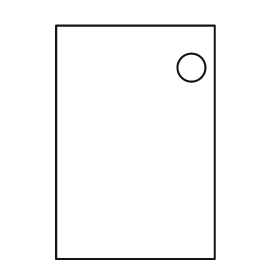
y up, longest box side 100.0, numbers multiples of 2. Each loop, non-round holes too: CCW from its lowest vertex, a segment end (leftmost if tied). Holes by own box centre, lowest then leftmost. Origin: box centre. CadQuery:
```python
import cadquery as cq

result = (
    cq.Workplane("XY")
    .moveTo(-34.0, -50.0)
    .lineTo(34.0, -50.0)
    .lineTo(34.0, 50.0)
    .lineTo(-34.0, 50.0)
    .close()
    .moveTo(24.0, 32.0)
    .circle(6.0)
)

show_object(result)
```